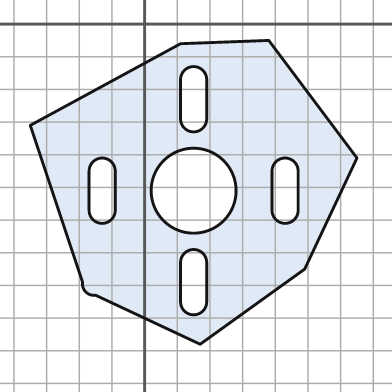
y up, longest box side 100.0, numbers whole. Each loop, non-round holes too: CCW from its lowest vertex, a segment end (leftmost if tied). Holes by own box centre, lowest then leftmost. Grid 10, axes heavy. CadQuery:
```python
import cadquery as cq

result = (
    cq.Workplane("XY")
    .moveTo(17.0, -98.0)
    .lineTo(49.0, -75.0)
    .lineTo(65.0, -41.0)
    .lineTo(38.0, -5.0)
    .lineTo(11.0, -6.0)
    .lineTo(-35.0, -31.0)
    .lineTo(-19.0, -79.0)
    .threePointArc((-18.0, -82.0), (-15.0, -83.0))
    .close()
    .moveTo(11.0, -85.0)
    .threePointArc((15.0, -89.0), (19.0, -85.0))
    .lineTo(19.0, -73.0)
    .threePointArc((15.0, -69.0), (11.0, -73.0))
    .close()
    .moveTo(-17.0, -57.0)
    .threePointArc((-13.0, -61.0), (-9.0, -57.0))
    .lineTo(-9.0, -45.0)
    .threePointArc((-13.0, -41.0), (-17.0, -45.0))
    .close()
    .moveTo(15.0, -51.0)
    .circle(13.0)
    .moveTo(39.0, -57.0)
    .threePointArc((43.0, -61.0), (47.0, -57.0))
    .lineTo(47.0, -45.0)
    .threePointArc((43.0, -41.0), (39.0, -45.0))
    .close()
    .moveTo(11.0, -29.0)
    .threePointArc((15.0, -33.0), (19.0, -29.0))
    .lineTo(19.0, -17.0)
    .threePointArc((15.0, -13.0), (11.0, -17.0))
    .close()
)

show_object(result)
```